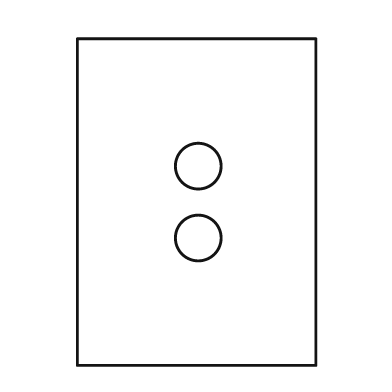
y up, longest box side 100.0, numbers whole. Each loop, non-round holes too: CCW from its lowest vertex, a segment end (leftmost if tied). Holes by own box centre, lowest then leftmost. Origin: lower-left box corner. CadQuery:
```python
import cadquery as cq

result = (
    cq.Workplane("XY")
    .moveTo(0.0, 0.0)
    .lineTo(73.0, 0.0)
    .lineTo(73.0, 100.0)
    .lineTo(0.0, 100.0)
    .close()
    .moveTo(37.0, 39.0)
    .circle(7.0)
    .moveTo(37.0, 61.0)
    .circle(7.0)
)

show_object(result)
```